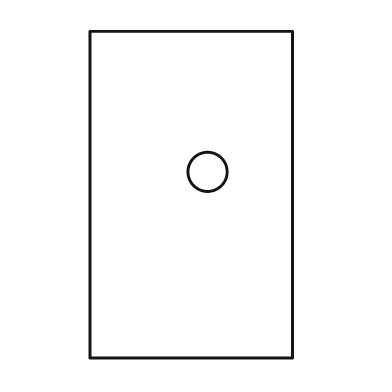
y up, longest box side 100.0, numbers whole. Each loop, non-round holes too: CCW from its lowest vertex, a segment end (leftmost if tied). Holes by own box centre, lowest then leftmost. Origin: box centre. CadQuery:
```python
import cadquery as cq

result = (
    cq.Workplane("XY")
    .moveTo(-31.0, -50.0)
    .lineTo(31.0, -50.0)
    .lineTo(31.0, 50.0)
    .lineTo(-31.0, 50.0)
    .close()
    .moveTo(5.0, 7.0)
    .circle(6.0)
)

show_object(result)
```